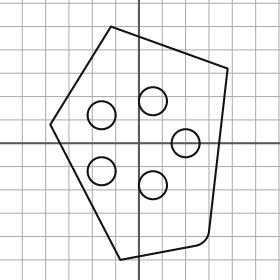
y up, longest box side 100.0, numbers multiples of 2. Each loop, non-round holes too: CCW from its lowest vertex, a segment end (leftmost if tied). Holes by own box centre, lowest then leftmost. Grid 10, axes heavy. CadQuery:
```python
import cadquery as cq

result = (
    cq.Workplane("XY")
    .moveTo(-8.0, -50.0)
    .lineTo(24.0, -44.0)
    .threePointArc((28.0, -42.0), (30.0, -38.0))
    .lineTo(38.0, 32.0)
    .lineTo(-12.0, 50.0)
    .lineTo(-38.0, 8.0)
    .close()
    .moveTo(6.0, -18.0)
    .circle(6.0)
    .moveTo(-16.0, -12.0)
    .circle(6.0)
    .moveTo(20.0, 0.0)
    .circle(6.0)
    .moveTo(-16.0, 12.0)
    .circle(6.0)
    .moveTo(6.0, 18.0)
    .circle(6.0)
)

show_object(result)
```